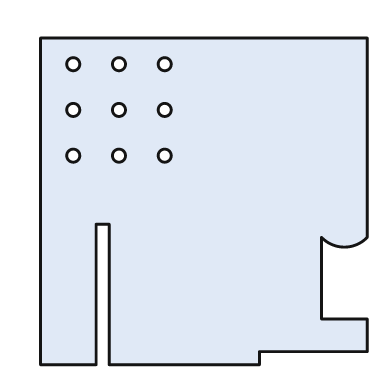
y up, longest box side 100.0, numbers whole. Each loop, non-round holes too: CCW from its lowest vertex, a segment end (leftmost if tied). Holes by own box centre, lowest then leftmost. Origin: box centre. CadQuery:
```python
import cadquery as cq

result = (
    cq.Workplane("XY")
    .moveTo(-50.0, -50.0)
    .lineTo(-33.0, -50.0)
    .lineTo(-33.0, -7.0)
    .lineTo(-29.0, -7.0)
    .lineTo(-29.0, -50.0)
    .lineTo(17.0, -50.0)
    .lineTo(17.0, -46.0)
    .lineTo(50.0, -46.0)
    .lineTo(50.0, -36.0)
    .lineTo(36.0, -36.0)
    .lineTo(36.0, -11.0)
    .threePointArc((43.0, -14.0), (50.0, -11.0))
    .lineTo(50.0, 50.0)
    .lineTo(-50.0, 50.0)
    .close()
    .moveTo(-40.0, 14.0)
    .circle(2.0)
    .moveTo(-26.0, 14.0)
    .circle(2.0)
    .moveTo(-12.0, 14.0)
    .circle(2.0)
    .moveTo(-40.0, 28.0)
    .circle(2.0)
    .moveTo(-26.0, 28.0)
    .circle(2.0)
    .moveTo(-12.0, 28.0)
    .circle(2.0)
    .moveTo(-40.0, 42.0)
    .circle(2.0)
    .moveTo(-26.0, 42.0)
    .circle(2.0)
    .moveTo(-12.0, 42.0)
    .circle(2.0)
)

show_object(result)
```